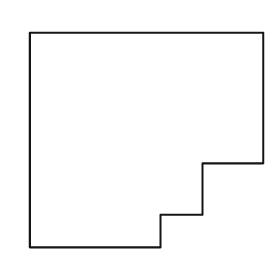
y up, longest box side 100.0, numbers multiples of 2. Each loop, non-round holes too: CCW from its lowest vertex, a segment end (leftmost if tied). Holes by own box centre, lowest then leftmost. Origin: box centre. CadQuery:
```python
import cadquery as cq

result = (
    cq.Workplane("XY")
    .moveTo(-50.0, -46.0)
    .lineTo(6.0, -46.0)
    .lineTo(6.0, -32.0)
    .lineTo(24.0, -32.0)
    .lineTo(24.0, -10.0)
    .lineTo(50.0, -10.0)
    .lineTo(50.0, 46.0)
    .lineTo(-50.0, 46.0)
    .close()
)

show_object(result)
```